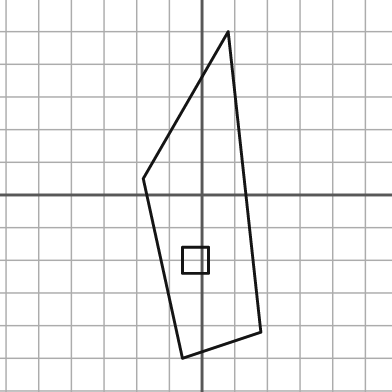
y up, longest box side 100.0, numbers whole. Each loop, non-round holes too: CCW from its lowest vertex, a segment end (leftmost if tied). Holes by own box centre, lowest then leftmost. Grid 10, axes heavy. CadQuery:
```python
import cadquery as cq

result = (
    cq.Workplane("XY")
    .moveTo(-6.0, -50.0)
    .lineTo(18.0, -42.0)
    .lineTo(8.0, 50.0)
    .lineTo(-18.0, 5.0)
    .close()
    .moveTo(-6.0, -24.0)
    .lineTo(2.0, -24.0)
    .lineTo(2.0, -16.0)
    .lineTo(-6.0, -16.0)
    .close()
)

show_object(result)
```